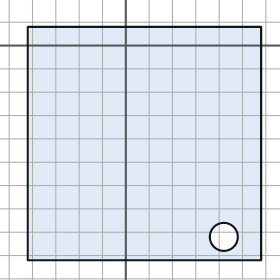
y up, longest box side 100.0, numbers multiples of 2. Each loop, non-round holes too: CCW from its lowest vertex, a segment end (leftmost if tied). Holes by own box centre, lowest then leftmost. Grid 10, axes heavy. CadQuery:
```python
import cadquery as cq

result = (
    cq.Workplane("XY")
    .moveTo(-42.0, -92.0)
    .lineTo(58.0, -92.0)
    .lineTo(58.0, 8.0)
    .lineTo(-42.0, 8.0)
    .close()
    .moveTo(42.0, -82.0)
    .circle(6.0)
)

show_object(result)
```